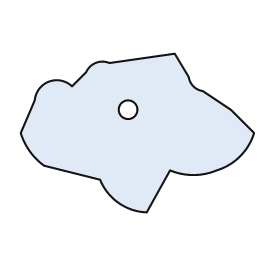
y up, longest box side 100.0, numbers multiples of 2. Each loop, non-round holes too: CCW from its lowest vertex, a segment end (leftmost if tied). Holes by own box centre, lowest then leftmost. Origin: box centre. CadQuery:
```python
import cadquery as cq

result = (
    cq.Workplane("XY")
    .moveTo(4.0, -34.0)
    .lineTo(14.0, -16.0)
    .threePointArc((24.0, -18.0), (34.0, -16.0))
    .threePointArc((44.0, -10.0), (50.0, 0.0))
    .lineTo(40.0, 10.0)
    .lineTo(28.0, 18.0)
    .threePointArc((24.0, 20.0), (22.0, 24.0))
    .lineTo(16.0, 34.0)
    .lineTo(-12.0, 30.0)
    .threePointArc((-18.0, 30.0), (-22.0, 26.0))
    .lineTo(-28.0, 20.0)
    .threePointArc((-38.0, 22.0), (-44.0, 14.0))
    .lineTo(-50.0, 0.0)
    .threePointArc((-46.0, -8.0), (-40.0, -14.0))
    .lineTo(-16.0, -20.0)
    .threePointArc((-8.0, -30.0), (4.0, -34.0))
    .close()
    .moveTo(-4.0, 10.0)
    .circle(4.0)
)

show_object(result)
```